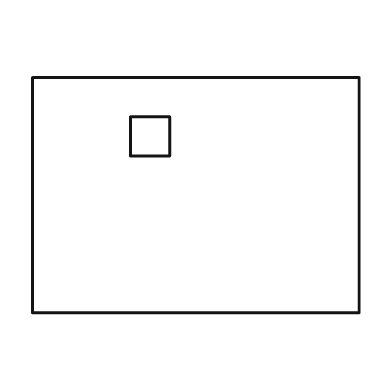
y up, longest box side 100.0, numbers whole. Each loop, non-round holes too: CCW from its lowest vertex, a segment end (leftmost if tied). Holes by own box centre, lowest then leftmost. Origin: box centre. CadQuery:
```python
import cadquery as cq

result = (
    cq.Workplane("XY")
    .moveTo(-50.0, -36.0)
    .lineTo(50.0, -36.0)
    .lineTo(50.0, 36.0)
    .lineTo(-50.0, 36.0)
    .close()
    .moveTo(-20.0, 12.0)
    .lineTo(-8.0, 12.0)
    .lineTo(-8.0, 24.0)
    .lineTo(-20.0, 24.0)
    .close()
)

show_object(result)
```